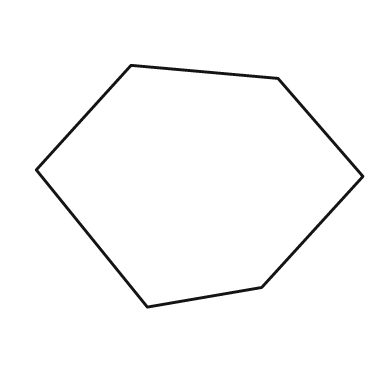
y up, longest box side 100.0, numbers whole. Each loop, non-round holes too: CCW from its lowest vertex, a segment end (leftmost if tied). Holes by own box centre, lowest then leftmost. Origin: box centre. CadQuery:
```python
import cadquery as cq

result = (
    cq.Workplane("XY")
    .moveTo(-16.0, -37.0)
    .lineTo(19.0, -31.0)
    .lineTo(50.0, 3.0)
    .lineTo(24.0, 33.0)
    .lineTo(-21.0, 37.0)
    .lineTo(-50.0, 5.0)
    .close()
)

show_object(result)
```